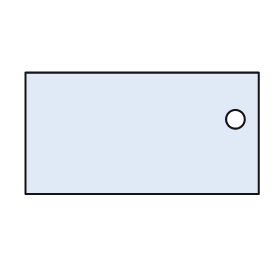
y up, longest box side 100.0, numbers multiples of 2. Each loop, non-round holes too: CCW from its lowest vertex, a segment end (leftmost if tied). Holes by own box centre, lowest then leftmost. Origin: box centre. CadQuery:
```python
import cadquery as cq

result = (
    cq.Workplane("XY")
    .moveTo(-50.0, -26.0)
    .lineTo(50.0, -26.0)
    .lineTo(50.0, 26.0)
    .lineTo(-50.0, 26.0)
    .close()
    .moveTo(40.0, 6.0)
    .circle(4.0)
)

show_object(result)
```